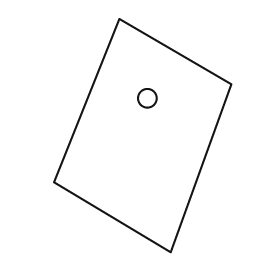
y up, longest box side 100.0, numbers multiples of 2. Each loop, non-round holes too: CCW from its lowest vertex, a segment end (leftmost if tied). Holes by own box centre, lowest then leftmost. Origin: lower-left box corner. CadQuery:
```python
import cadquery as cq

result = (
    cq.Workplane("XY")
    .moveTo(50.0, 0.0)
    .lineTo(76.0, 72.0)
    .lineTo(28.0, 100.0)
    .lineTo(0.0, 30.0)
    .close()
    .moveTo(40.0, 66.0)
    .circle(4.0)
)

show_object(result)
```